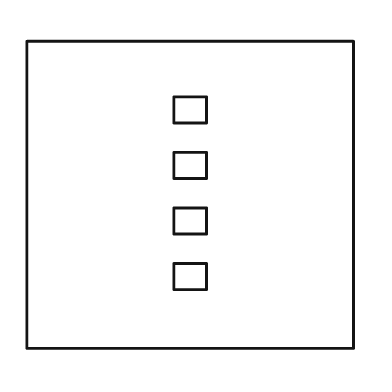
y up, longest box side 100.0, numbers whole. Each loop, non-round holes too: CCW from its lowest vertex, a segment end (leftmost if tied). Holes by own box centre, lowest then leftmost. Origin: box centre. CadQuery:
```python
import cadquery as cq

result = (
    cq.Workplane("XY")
    .moveTo(-50.0, -47.0)
    .lineTo(50.0, -47.0)
    .lineTo(50.0, 47.0)
    .lineTo(-50.0, 47.0)
    .close()
    .moveTo(-5.0, -29.0)
    .lineTo(5.0, -29.0)
    .lineTo(5.0, -21.0)
    .lineTo(-5.0, -21.0)
    .close()
    .moveTo(-5.0, -12.0)
    .lineTo(5.0, -12.0)
    .lineTo(5.0, -4.0)
    .lineTo(-5.0, -4.0)
    .close()
    .moveTo(-5.0, 5.0)
    .lineTo(5.0, 5.0)
    .lineTo(5.0, 13.0)
    .lineTo(-5.0, 13.0)
    .close()
    .moveTo(-5.0, 22.0)
    .lineTo(5.0, 22.0)
    .lineTo(5.0, 30.0)
    .lineTo(-5.0, 30.0)
    .close()
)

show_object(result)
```